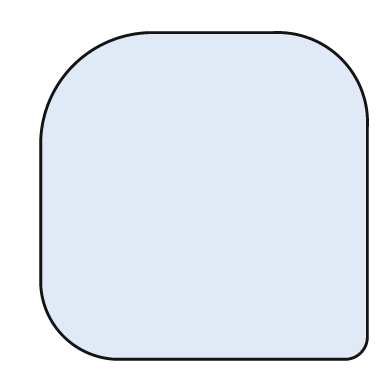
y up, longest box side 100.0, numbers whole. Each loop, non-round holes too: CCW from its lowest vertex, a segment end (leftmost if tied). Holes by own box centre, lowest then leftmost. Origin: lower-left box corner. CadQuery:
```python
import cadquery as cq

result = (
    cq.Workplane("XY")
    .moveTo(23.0, 0.0)
    .lineTo(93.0, 0.0)
    .threePointArc((98.0, 2.0), (100.0, 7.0))
    .lineTo(100.0, 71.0)
    .threePointArc((92.0, 92.0), (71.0, 100.0))
    .lineTo(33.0, 100.0)
    .threePointArc((10.0, 90.0), (0.0, 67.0))
    .lineTo(0.0, 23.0)
    .threePointArc((7.0, 7.0), (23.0, 0.0))
    .close()
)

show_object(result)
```